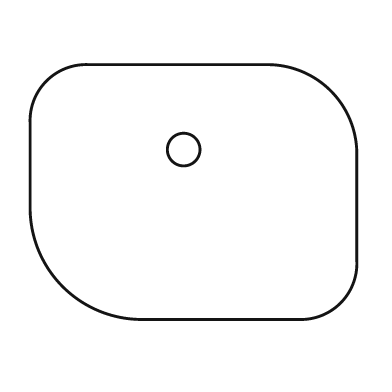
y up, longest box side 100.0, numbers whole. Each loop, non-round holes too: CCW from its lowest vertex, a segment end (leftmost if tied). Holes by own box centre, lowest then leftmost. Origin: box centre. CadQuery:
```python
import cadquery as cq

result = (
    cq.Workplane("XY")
    .moveTo(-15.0, -39.0)
    .lineTo(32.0, -39.0)
    .threePointArc((45.0, -34.0), (50.0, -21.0))
    .lineTo(50.0, 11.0)
    .threePointArc((42.0, 31.0), (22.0, 39.0))
    .lineTo(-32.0, 39.0)
    .threePointArc((-45.0, 34.0), (-50.0, 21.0))
    .lineTo(-50.0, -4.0)
    .threePointArc((-40.0, -29.0), (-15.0, -39.0))
    .close()
    .moveTo(-3.0, 13.0)
    .circle(5.0)
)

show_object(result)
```